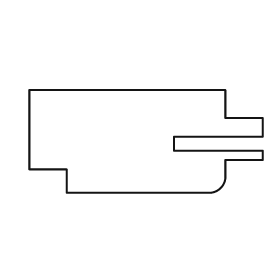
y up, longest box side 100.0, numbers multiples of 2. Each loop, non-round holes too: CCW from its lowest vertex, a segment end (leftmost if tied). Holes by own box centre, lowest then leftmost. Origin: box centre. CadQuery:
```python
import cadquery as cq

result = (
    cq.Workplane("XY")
    .moveTo(-34.0, -22.0)
    .lineTo(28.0, -22.0)
    .threePointArc((32.0, -20.0), (34.0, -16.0))
    .lineTo(34.0, -8.0)
    .lineTo(50.0, -8.0)
    .lineTo(50.0, -4.0)
    .lineTo(12.0, -4.0)
    .lineTo(12.0, 2.0)
    .lineTo(50.0, 2.0)
    .lineTo(50.0, 10.0)
    .lineTo(34.0, 10.0)
    .lineTo(34.0, 22.0)
    .lineTo(-50.0, 22.0)
    .lineTo(-50.0, -12.0)
    .lineTo(-34.0, -12.0)
    .close()
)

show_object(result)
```